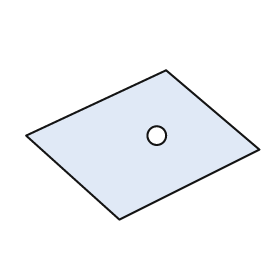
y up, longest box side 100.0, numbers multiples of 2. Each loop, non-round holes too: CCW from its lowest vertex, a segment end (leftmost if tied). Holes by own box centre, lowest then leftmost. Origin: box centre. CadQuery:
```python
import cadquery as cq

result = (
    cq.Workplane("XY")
    .moveTo(-10.0, -32.0)
    .lineTo(50.0, -2.0)
    .lineTo(10.0, 32.0)
    .lineTo(-50.0, 4.0)
    .close()
    .moveTo(6.0, 4.0)
    .circle(4.0)
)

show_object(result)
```